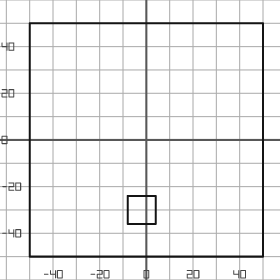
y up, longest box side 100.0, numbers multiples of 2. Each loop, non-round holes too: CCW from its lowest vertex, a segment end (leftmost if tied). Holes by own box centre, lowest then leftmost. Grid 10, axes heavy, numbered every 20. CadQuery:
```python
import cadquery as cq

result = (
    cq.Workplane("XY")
    .moveTo(-50.0, -50.0)
    .lineTo(50.0, -50.0)
    .lineTo(50.0, 50.0)
    .lineTo(-50.0, 50.0)
    .close()
    .moveTo(-8.0, -36.0)
    .lineTo(4.0, -36.0)
    .lineTo(4.0, -24.0)
    .lineTo(-8.0, -24.0)
    .close()
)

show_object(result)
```